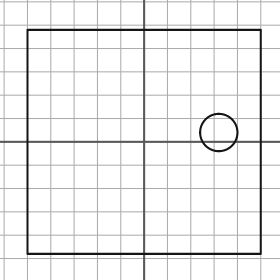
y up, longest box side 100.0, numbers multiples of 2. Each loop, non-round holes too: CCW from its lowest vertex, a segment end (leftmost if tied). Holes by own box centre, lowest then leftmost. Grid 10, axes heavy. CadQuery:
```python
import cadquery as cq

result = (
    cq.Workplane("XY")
    .moveTo(-50.0, -48.0)
    .lineTo(50.0, -48.0)
    .lineTo(50.0, 48.0)
    .lineTo(-50.0, 48.0)
    .close()
    .moveTo(32.0, 4.0)
    .circle(8.0)
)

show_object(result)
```